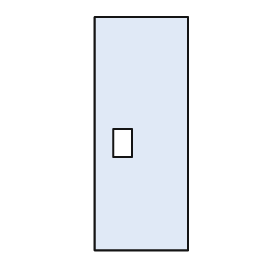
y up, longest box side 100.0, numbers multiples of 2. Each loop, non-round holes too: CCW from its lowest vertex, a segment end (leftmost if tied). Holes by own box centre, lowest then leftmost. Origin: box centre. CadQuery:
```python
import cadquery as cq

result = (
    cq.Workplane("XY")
    .moveTo(-20.0, -50.0)
    .lineTo(20.0, -50.0)
    .lineTo(20.0, 50.0)
    .lineTo(-20.0, 50.0)
    .close()
    .moveTo(-12.0, -10.0)
    .lineTo(-4.0, -10.0)
    .lineTo(-4.0, 2.0)
    .lineTo(-12.0, 2.0)
    .close()
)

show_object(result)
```